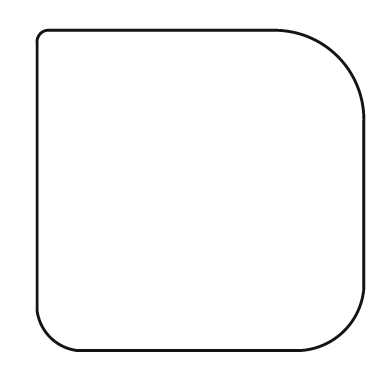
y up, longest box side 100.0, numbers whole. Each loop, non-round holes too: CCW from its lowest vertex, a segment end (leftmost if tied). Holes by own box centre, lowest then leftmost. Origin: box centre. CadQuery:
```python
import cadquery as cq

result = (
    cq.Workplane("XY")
    .moveTo(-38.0, -49.0)
    .lineTo(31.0, -49.0)
    .threePointArc((44.0, -43.0), (50.0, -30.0))
    .lineTo(50.0, 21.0)
    .threePointArc((42.0, 41.0), (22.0, 49.0))
    .lineTo(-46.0, 49.0)
    .threePointArc((-49.0, 48.0), (-50.0, 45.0))
    .lineTo(-50.0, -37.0)
    .threePointArc((-46.0, -45.0), (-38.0, -49.0))
    .close()
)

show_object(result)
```